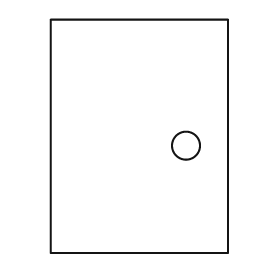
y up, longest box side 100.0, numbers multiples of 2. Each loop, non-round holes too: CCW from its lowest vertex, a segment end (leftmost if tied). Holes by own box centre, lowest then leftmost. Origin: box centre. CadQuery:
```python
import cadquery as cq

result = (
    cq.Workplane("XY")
    .moveTo(-38.0, -50.0)
    .lineTo(38.0, -50.0)
    .lineTo(38.0, 50.0)
    .lineTo(-38.0, 50.0)
    .close()
    .moveTo(20.0, -4.0)
    .circle(6.0)
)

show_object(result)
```